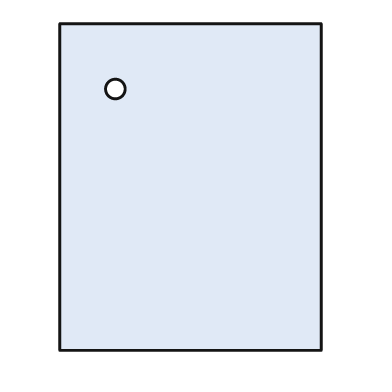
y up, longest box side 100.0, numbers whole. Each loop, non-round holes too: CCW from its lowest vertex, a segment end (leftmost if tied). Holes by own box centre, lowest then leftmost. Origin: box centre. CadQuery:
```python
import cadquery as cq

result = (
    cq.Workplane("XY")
    .moveTo(-40.0, -50.0)
    .lineTo(40.0, -50.0)
    .lineTo(40.0, 50.0)
    .lineTo(-40.0, 50.0)
    .close()
    .moveTo(-23.0, 30.0)
    .circle(3.0)
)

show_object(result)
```